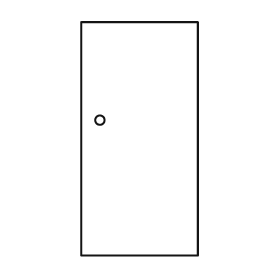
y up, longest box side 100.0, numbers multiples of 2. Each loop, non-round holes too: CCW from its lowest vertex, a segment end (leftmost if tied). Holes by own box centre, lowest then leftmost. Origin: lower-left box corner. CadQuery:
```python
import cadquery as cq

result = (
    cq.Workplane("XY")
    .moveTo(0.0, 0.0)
    .lineTo(50.0, 0.0)
    .lineTo(50.0, 100.0)
    .lineTo(0.0, 100.0)
    .close()
    .moveTo(8.0, 58.0)
    .circle(2.0)
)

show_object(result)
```